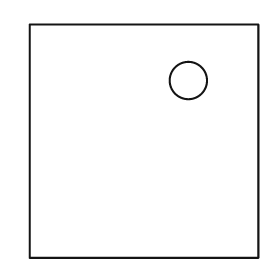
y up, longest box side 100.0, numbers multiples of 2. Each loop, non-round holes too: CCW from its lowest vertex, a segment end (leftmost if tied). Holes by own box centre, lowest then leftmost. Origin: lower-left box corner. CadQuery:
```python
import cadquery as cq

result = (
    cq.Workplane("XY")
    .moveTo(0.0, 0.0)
    .lineTo(98.0, 0.0)
    .lineTo(98.0, 100.0)
    .lineTo(0.0, 100.0)
    .close()
    .moveTo(68.0, 76.0)
    .circle(8.0)
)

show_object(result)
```